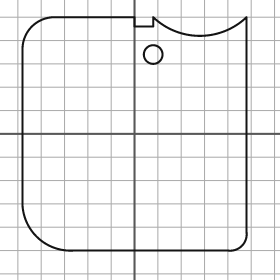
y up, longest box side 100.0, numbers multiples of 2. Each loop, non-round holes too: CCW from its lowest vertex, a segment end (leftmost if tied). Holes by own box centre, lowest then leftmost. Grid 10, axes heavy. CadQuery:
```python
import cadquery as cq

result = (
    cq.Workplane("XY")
    .moveTo(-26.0, -50.0)
    .lineTo(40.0, -50.0)
    .threePointArc((46.0, -48.0), (48.0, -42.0))
    .lineTo(48.0, 50.0)
    .threePointArc((28.0, 42.0), (8.0, 50.0))
    .lineTo(8.0, 46.0)
    .lineTo(0.0, 46.0)
    .lineTo(0.0, 50.0)
    .lineTo(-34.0, 50.0)
    .threePointArc((-44.0, 46.0), (-48.0, 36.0))
    .lineTo(-48.0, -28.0)
    .threePointArc((-42.0, -44.0), (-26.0, -50.0))
    .close()
    .moveTo(8.0, 34.0)
    .circle(4.0)
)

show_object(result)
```